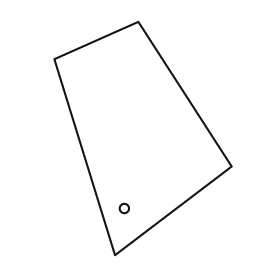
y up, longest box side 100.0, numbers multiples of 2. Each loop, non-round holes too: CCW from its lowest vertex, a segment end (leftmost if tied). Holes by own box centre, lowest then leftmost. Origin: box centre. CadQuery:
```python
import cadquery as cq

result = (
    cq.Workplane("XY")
    .moveTo(-12.0, -50.0)
    .lineTo(38.0, -12.0)
    .lineTo(-2.0, 50.0)
    .lineTo(-38.0, 34.0)
    .close()
    .moveTo(-8.0, -30.0)
    .circle(2.0)
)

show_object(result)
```